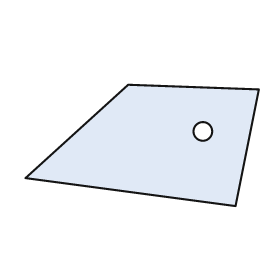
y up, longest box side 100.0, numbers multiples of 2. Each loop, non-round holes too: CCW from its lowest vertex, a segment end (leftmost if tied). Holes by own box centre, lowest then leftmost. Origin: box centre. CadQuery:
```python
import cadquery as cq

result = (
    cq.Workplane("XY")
    .moveTo(40.0, -26.0)
    .lineTo(50.0, 24.0)
    .lineTo(-6.0, 26.0)
    .lineTo(-50.0, -14.0)
    .close()
    .moveTo(26.0, 6.0)
    .circle(4.0)
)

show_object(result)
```